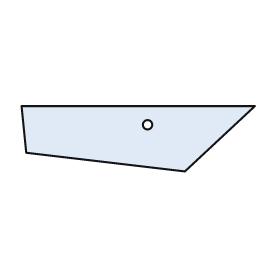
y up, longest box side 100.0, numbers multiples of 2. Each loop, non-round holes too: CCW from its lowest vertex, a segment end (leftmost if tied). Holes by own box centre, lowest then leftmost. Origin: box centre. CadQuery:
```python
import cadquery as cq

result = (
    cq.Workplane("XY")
    .moveTo(20.0, -14.0)
    .lineTo(50.0, 14.0)
    .lineTo(-50.0, 14.0)
    .lineTo(-48.0, -6.0)
    .close()
    .moveTo(4.0, 6.0)
    .circle(2.0)
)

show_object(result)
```